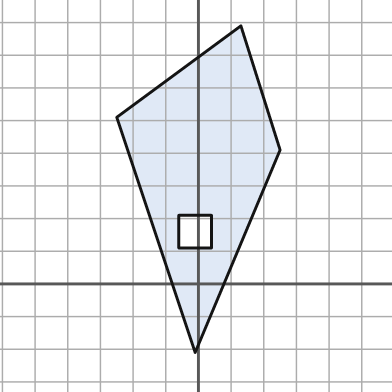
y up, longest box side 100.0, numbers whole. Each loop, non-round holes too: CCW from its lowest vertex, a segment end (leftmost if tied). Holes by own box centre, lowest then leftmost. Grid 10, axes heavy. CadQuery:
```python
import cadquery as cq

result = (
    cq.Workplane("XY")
    .moveTo(-1.0, -21.0)
    .lineTo(25.0, 41.0)
    .lineTo(13.0, 79.0)
    .lineTo(-25.0, 51.0)
    .close()
    .moveTo(-6.0, 11.0)
    .lineTo(4.0, 11.0)
    .lineTo(4.0, 21.0)
    .lineTo(-6.0, 21.0)
    .close()
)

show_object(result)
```